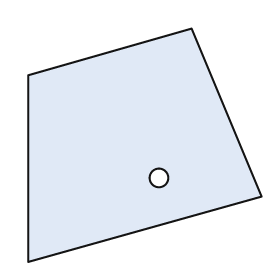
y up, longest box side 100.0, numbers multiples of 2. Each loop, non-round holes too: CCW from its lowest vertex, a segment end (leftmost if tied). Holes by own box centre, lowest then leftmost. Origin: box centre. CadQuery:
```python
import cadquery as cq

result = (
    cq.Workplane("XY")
    .moveTo(-50.0, -50.0)
    .lineTo(50.0, -22.0)
    .lineTo(20.0, 50.0)
    .lineTo(-50.0, 30.0)
    .close()
    .moveTo(6.0, -14.0)
    .circle(4.0)
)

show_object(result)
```